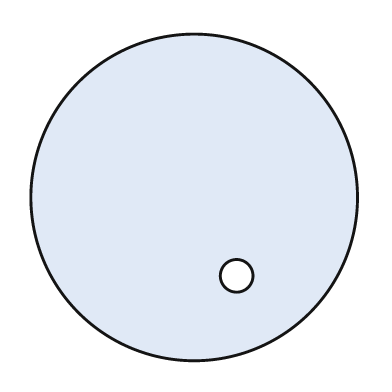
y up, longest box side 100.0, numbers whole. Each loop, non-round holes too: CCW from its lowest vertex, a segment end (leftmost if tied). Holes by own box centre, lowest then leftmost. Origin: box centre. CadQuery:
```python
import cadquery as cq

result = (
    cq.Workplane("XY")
    .moveTo(0.0, 0.0)
    .circle(50.0)
    .moveTo(13.0, -24.0)
    .circle(5.0)
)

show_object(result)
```